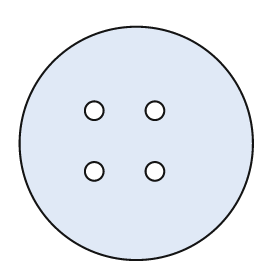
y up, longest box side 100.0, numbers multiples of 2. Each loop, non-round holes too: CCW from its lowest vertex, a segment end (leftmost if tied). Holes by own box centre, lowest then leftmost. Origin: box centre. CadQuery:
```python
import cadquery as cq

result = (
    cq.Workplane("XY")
    .moveTo(0.0, 0.0)
    .circle(50.0)
    .moveTo(-18.0, -12.0)
    .circle(4.0)
    .moveTo(8.0, -12.0)
    .circle(4.0)
    .moveTo(-18.0, 14.0)
    .circle(4.0)
    .moveTo(8.0, 14.0)
    .circle(4.0)
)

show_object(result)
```